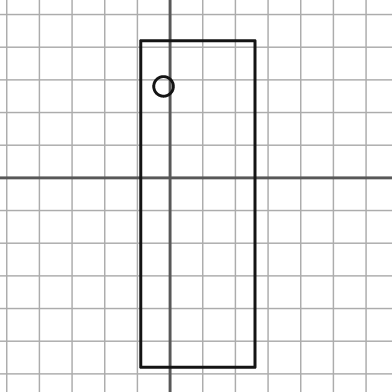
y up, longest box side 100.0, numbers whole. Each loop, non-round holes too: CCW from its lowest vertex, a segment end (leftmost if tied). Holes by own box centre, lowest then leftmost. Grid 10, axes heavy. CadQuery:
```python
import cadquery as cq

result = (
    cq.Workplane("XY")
    .moveTo(-9.0, -58.0)
    .lineTo(26.0, -58.0)
    .lineTo(26.0, 42.0)
    .lineTo(-9.0, 42.0)
    .close()
    .moveTo(-2.0, 28.0)
    .circle(3.0)
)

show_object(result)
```